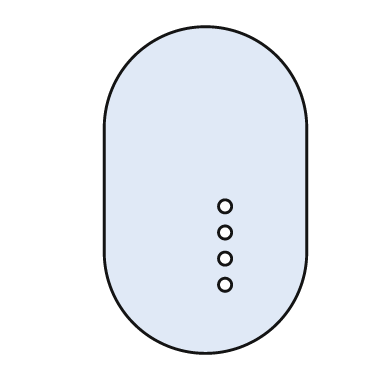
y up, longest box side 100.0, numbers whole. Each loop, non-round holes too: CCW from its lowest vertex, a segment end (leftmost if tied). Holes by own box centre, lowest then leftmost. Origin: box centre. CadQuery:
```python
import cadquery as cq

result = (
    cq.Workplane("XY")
    .moveTo(-31.0, -19.0)
    .threePointArc((0.0, -50.0), (31.0, -19.0))
    .lineTo(31.0, 19.0)
    .threePointArc((0.0, 50.0), (-31.0, 19.0))
    .close()
    .moveTo(6.0, -29.0)
    .circle(2.0)
    .moveTo(6.0, -21.0)
    .circle(2.0)
    .moveTo(6.0, -13.0)
    .circle(2.0)
    .moveTo(6.0, -5.0)
    .circle(2.0)
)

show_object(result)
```